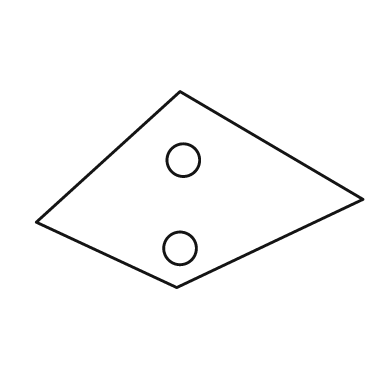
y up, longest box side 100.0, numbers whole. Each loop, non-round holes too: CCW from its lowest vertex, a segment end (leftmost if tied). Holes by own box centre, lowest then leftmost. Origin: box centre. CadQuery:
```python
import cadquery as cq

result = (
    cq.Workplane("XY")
    .moveTo(-7.0, -30.0)
    .lineTo(50.0, -3.0)
    .lineTo(-6.0, 30.0)
    .lineTo(-50.0, -10.0)
    .close()
    .moveTo(-6.0, -18.0)
    .circle(5.0)
    .moveTo(-5.0, 9.0)
    .circle(5.0)
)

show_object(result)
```